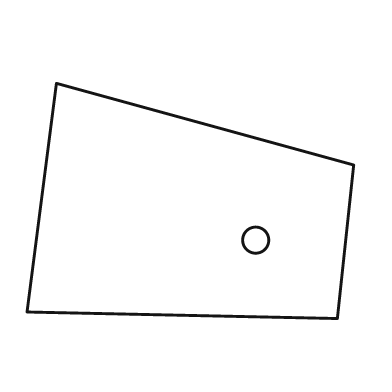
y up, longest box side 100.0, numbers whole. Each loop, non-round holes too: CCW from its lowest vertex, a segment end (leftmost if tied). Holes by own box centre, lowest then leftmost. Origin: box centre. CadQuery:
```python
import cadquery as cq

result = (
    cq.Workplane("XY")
    .moveTo(45.0, -36.0)
    .lineTo(50.0, 11.0)
    .lineTo(-41.0, 36.0)
    .lineTo(-50.0, -34.0)
    .close()
    .moveTo(20.0, -12.0)
    .circle(4.0)
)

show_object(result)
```